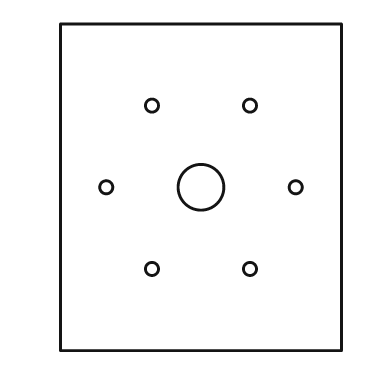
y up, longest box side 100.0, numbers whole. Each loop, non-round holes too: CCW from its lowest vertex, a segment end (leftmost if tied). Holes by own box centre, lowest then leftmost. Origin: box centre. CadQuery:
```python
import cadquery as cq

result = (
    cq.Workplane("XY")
    .moveTo(-43.0, -50.0)
    .lineTo(43.0, -50.0)
    .lineTo(43.0, 50.0)
    .lineTo(-43.0, 50.0)
    .close()
    .moveTo(-15.0, -25.0)
    .circle(2.0)
    .moveTo(15.0, -25.0)
    .circle(2.0)
    .moveTo(-29.0, 0.0)
    .circle(2.0)
    .moveTo(0.0, 0.0)
    .circle(7.0)
    .moveTo(29.0, 0.0)
    .circle(2.0)
    .moveTo(-15.0, 25.0)
    .circle(2.0)
    .moveTo(15.0, 25.0)
    .circle(2.0)
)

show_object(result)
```